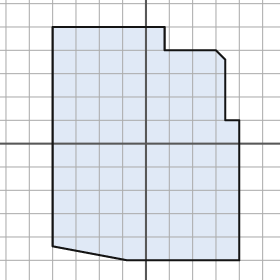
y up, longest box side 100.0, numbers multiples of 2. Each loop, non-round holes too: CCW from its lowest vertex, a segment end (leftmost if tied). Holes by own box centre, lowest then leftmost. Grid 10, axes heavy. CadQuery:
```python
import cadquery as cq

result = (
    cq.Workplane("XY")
    .moveTo(-8.0, -50.0)
    .lineTo(40.0, -50.0)
    .lineTo(40.0, 10.0)
    .lineTo(34.0, 10.0)
    .lineTo(34.0, 36.0)
    .lineTo(30.0, 40.0)
    .lineTo(8.0, 40.0)
    .lineTo(8.0, 50.0)
    .lineTo(-40.0, 50.0)
    .lineTo(-40.0, -44.0)
    .close()
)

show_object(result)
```